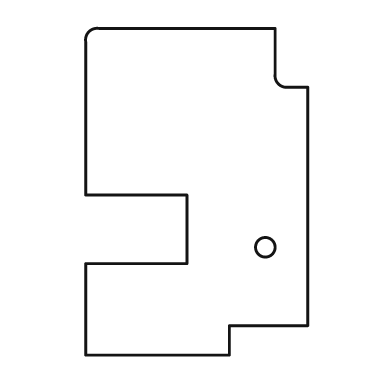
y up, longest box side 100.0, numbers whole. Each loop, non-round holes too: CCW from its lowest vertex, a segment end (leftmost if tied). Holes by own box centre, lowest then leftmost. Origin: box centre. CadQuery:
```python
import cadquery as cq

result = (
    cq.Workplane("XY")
    .moveTo(-34.0, -50.0)
    .lineTo(10.0, -50.0)
    .lineTo(10.0, -41.0)
    .lineTo(34.0, -41.0)
    .lineTo(34.0, 32.0)
    .lineTo(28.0, 32.0)
    .threePointArc((25.0, 33.0), (24.0, 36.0))
    .lineTo(24.0, 50.0)
    .lineTo(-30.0, 50.0)
    .threePointArc((-33.0, 49.0), (-34.0, 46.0))
    .lineTo(-34.0, -1.0)
    .lineTo(-3.0, -1.0)
    .lineTo(-3.0, -22.0)
    .lineTo(-34.0, -22.0)
    .close()
    .moveTo(21.0, -17.0)
    .circle(3.0)
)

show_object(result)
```